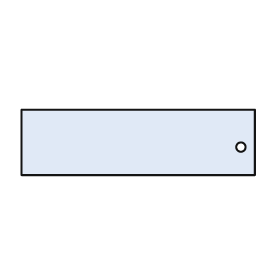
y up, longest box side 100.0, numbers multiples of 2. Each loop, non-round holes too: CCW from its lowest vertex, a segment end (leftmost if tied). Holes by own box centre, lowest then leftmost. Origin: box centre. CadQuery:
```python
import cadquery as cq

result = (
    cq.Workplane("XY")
    .moveTo(-50.0, -14.0)
    .lineTo(50.0, -14.0)
    .lineTo(50.0, 14.0)
    .lineTo(-50.0, 14.0)
    .close()
    .moveTo(44.0, -2.0)
    .circle(2.0)
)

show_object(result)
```